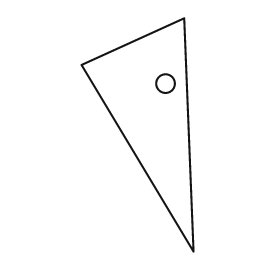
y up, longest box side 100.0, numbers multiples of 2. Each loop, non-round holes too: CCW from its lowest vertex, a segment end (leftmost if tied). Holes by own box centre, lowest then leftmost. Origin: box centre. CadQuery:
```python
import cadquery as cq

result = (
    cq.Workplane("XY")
    .moveTo(24.0, -50.0)
    .lineTo(20.0, 50.0)
    .lineTo(-24.0, 30.0)
    .close()
    .moveTo(12.0, 22.0)
    .circle(4.0)
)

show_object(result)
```